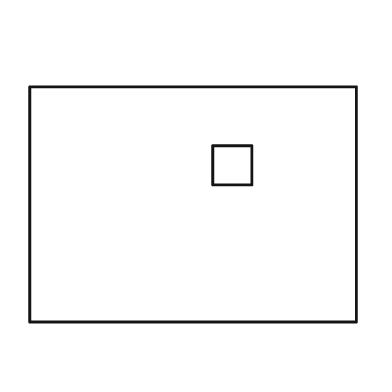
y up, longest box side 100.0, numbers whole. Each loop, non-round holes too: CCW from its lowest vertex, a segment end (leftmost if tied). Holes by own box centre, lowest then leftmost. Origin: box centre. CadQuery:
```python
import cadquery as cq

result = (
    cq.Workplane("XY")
    .moveTo(-50.0, -36.0)
    .lineTo(50.0, -36.0)
    .lineTo(50.0, 36.0)
    .lineTo(-50.0, 36.0)
    .close()
    .moveTo(6.0, 6.0)
    .lineTo(18.0, 6.0)
    .lineTo(18.0, 18.0)
    .lineTo(6.0, 18.0)
    .close()
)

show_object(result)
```